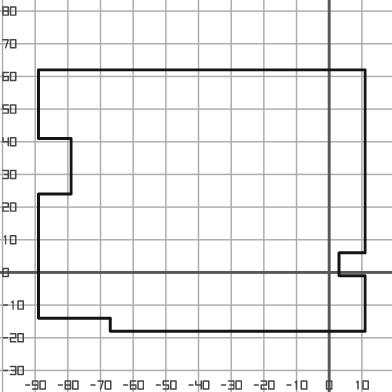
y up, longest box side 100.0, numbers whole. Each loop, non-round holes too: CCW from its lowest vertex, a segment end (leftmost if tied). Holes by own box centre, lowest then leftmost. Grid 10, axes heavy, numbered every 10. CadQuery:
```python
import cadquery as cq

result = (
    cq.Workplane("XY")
    .moveTo(-67.0, -18.0)
    .lineTo(11.0, -18.0)
    .lineTo(11.0, -1.0)
    .lineTo(3.0, -1.0)
    .lineTo(3.0, 6.0)
    .lineTo(11.0, 6.0)
    .lineTo(11.0, 62.0)
    .lineTo(-89.0, 62.0)
    .lineTo(-89.0, 41.0)
    .lineTo(-79.0, 41.0)
    .lineTo(-79.0, 24.0)
    .lineTo(-89.0, 24.0)
    .lineTo(-89.0, -14.0)
    .lineTo(-67.0, -14.0)
    .close()
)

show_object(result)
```